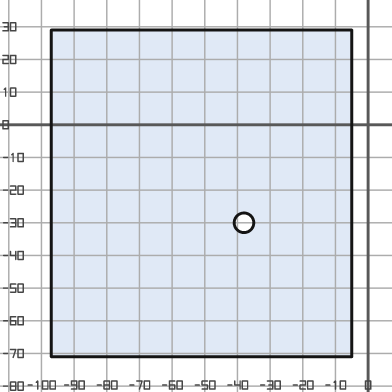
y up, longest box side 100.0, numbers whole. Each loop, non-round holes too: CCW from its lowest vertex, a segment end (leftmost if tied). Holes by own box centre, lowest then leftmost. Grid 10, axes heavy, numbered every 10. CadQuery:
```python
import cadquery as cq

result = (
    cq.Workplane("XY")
    .moveTo(-97.0, -71.0)
    .lineTo(-5.0, -71.0)
    .lineTo(-5.0, 29.0)
    .lineTo(-97.0, 29.0)
    .close()
    .moveTo(-38.0, -30.0)
    .circle(3.0)
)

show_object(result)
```